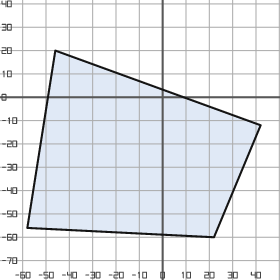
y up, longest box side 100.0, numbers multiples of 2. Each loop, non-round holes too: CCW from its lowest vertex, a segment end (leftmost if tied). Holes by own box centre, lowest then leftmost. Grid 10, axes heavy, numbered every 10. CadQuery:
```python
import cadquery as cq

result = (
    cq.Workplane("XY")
    .moveTo(22.0, -60.0)
    .lineTo(42.0, -12.0)
    .lineTo(-46.0, 20.0)
    .lineTo(-58.0, -56.0)
    .close()
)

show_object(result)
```